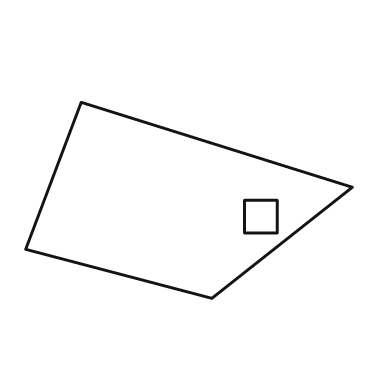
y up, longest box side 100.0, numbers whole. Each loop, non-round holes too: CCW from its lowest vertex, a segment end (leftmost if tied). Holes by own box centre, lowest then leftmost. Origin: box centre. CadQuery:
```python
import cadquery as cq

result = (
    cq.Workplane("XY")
    .moveTo(7.0, -30.0)
    .lineTo(50.0, 4.0)
    .lineTo(-33.0, 30.0)
    .lineTo(-50.0, -15.0)
    .close()
    .moveTo(17.0, -10.0)
    .lineTo(27.0, -10.0)
    .lineTo(27.0, 0.0)
    .lineTo(17.0, 0.0)
    .close()
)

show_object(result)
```